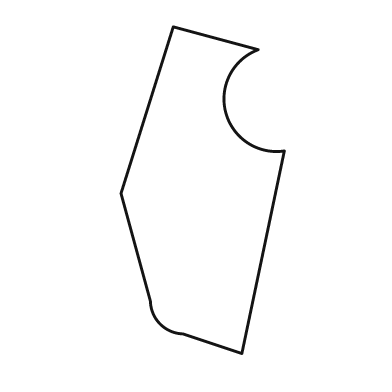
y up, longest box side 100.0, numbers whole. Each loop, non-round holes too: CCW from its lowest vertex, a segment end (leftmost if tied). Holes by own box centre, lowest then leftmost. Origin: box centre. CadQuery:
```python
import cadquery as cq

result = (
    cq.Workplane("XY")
    .moveTo(12.0, -50.0)
    .lineTo(25.0, 12.0)
    .threePointArc((7.0, 24.0), (17.0, 43.0))
    .lineTo(-9.0, 50.0)
    .lineTo(-25.0, -1.0)
    .lineTo(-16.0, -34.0)
    .threePointArc((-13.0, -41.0), (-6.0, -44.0))
    .close()
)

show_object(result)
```